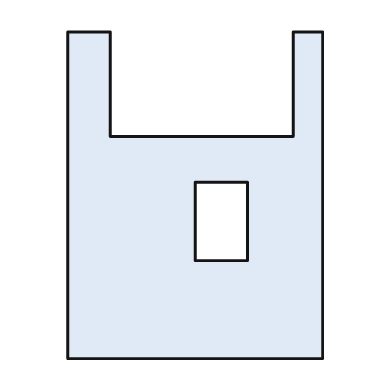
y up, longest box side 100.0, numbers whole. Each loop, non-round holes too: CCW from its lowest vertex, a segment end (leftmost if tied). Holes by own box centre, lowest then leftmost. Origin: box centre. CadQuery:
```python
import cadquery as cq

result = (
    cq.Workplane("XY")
    .moveTo(-39.0, -50.0)
    .lineTo(39.0, -50.0)
    .lineTo(39.0, 50.0)
    .lineTo(30.0, 50.0)
    .lineTo(30.0, 18.0)
    .lineTo(-26.0, 18.0)
    .lineTo(-26.0, 50.0)
    .lineTo(-39.0, 50.0)
    .close()
    .moveTo(0.0, -20.0)
    .lineTo(16.0, -20.0)
    .lineTo(16.0, 4.0)
    .lineTo(0.0, 4.0)
    .close()
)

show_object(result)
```